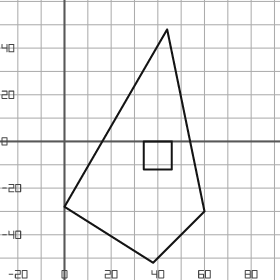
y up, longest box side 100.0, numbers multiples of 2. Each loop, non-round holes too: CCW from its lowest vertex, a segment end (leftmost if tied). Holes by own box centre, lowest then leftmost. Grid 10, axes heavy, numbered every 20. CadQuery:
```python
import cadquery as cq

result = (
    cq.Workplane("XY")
    .moveTo(38.0, -52.0)
    .lineTo(60.0, -30.0)
    .lineTo(44.0, 48.0)
    .lineTo(0.0, -28.0)
    .close()
    .moveTo(34.0, -12.0)
    .lineTo(46.0, -12.0)
    .lineTo(46.0, 0.0)
    .lineTo(34.0, 0.0)
    .close()
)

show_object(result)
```